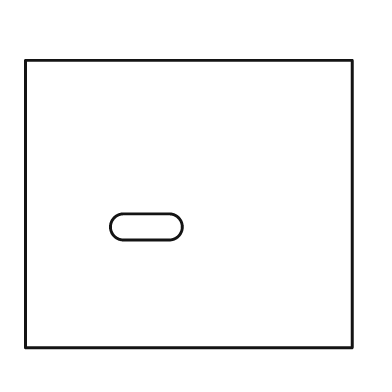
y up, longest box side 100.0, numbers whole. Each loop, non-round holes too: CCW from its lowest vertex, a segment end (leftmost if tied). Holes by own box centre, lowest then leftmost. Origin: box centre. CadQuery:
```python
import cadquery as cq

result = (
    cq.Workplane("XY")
    .moveTo(-50.0, -44.0)
    .lineTo(50.0, -44.0)
    .lineTo(50.0, 44.0)
    .lineTo(-50.0, 44.0)
    .close()
    .moveTo(-20.0, -11.0)
    .lineTo(-6.0, -11.0)
    .threePointArc((-2.0, -7.0), (-6.0, -3.0))
    .lineTo(-20.0, -3.0)
    .threePointArc((-24.0, -7.0), (-20.0, -11.0))
    .close()
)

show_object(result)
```